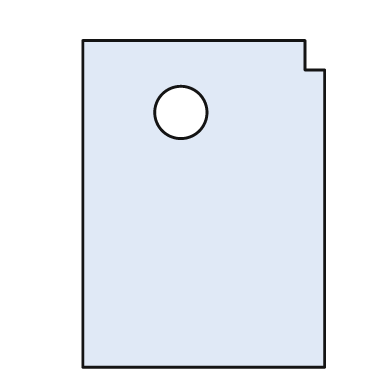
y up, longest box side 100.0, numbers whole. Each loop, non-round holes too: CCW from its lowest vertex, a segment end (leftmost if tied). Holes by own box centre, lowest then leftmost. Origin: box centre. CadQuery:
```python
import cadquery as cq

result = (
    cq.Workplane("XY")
    .moveTo(-37.0, -50.0)
    .lineTo(37.0, -50.0)
    .lineTo(37.0, 41.0)
    .lineTo(31.0, 41.0)
    .lineTo(31.0, 50.0)
    .lineTo(-37.0, 50.0)
    .close()
    .moveTo(-7.0, 28.0)
    .circle(8.0)
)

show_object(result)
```